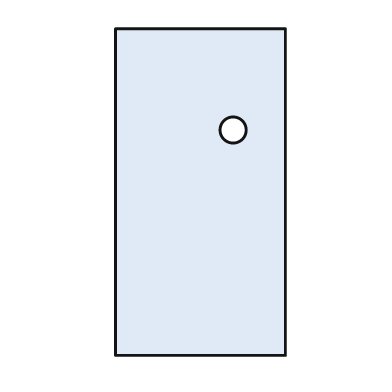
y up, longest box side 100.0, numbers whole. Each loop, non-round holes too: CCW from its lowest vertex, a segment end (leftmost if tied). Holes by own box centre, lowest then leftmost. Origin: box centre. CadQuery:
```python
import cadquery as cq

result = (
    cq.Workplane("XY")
    .moveTo(-26.0, -50.0)
    .lineTo(26.0, -50.0)
    .lineTo(26.0, 50.0)
    .lineTo(-26.0, 50.0)
    .close()
    .moveTo(10.0, 19.0)
    .circle(4.0)
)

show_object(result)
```